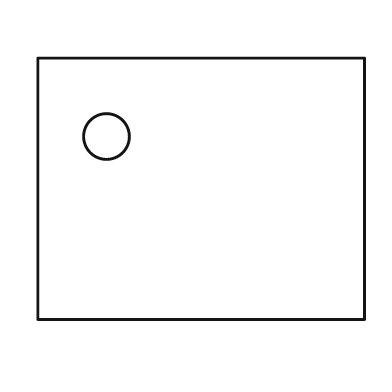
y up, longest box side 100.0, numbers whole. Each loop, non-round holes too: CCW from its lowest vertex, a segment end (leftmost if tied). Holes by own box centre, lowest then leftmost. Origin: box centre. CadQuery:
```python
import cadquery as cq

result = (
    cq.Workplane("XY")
    .moveTo(-50.0, -40.0)
    .lineTo(50.0, -40.0)
    .lineTo(50.0, 40.0)
    .lineTo(-50.0, 40.0)
    .close()
    .moveTo(-29.0, 16.0)
    .circle(7.0)
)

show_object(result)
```